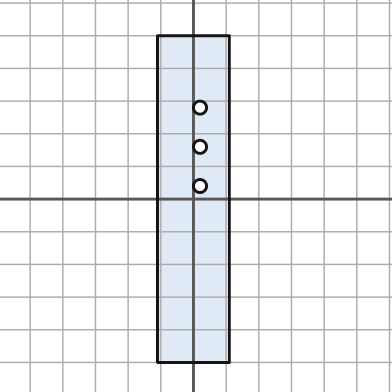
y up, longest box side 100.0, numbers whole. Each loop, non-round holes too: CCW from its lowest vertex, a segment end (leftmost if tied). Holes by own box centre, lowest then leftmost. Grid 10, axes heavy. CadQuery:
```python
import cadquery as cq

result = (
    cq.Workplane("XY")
    .moveTo(-11.0, -50.0)
    .lineTo(11.0, -50.0)
    .lineTo(11.0, 50.0)
    .lineTo(-11.0, 50.0)
    .close()
    .moveTo(2.0, 4.0)
    .circle(2.0)
    .moveTo(2.0, 16.0)
    .circle(2.0)
    .moveTo(2.0, 28.0)
    .circle(2.0)
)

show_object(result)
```